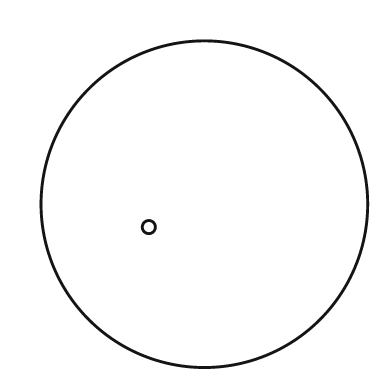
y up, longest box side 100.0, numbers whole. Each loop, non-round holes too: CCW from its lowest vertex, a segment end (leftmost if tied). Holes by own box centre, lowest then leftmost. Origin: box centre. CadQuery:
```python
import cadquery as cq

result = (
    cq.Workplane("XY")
    .moveTo(0.0, 0.0)
    .circle(50.0)
    .moveTo(-17.0, -7.0)
    .circle(2.0)
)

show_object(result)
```